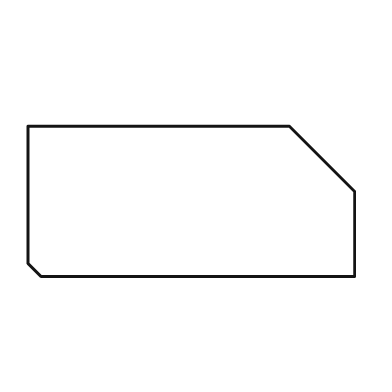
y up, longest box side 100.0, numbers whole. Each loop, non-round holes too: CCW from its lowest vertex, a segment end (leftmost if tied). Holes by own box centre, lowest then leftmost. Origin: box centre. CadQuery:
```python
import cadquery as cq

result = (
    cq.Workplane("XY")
    .moveTo(-46.0, -23.0)
    .lineTo(50.0, -23.0)
    .lineTo(50.0, 3.0)
    .lineTo(30.0, 23.0)
    .lineTo(-50.0, 23.0)
    .lineTo(-50.0, -19.0)
    .close()
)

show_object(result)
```